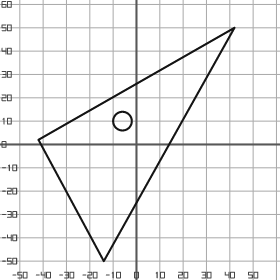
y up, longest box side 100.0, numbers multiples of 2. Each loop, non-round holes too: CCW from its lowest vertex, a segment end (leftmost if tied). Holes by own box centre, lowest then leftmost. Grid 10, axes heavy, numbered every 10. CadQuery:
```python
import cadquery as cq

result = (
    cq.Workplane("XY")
    .moveTo(-14.0, -50.0)
    .lineTo(42.0, 50.0)
    .lineTo(-42.0, 2.0)
    .close()
    .moveTo(-6.0, 10.0)
    .circle(4.0)
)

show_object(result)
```